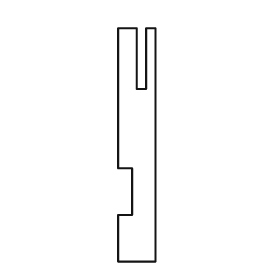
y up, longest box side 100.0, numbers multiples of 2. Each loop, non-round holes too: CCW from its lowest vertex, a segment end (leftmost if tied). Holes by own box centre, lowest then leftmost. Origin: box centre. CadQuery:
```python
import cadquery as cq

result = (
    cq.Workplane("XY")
    .moveTo(-8.0, -50.0)
    .lineTo(8.0, -50.0)
    .lineTo(8.0, 50.0)
    .lineTo(4.0, 50.0)
    .lineTo(4.0, 24.0)
    .lineTo(0.0, 24.0)
    .lineTo(0.0, 50.0)
    .lineTo(-8.0, 50.0)
    .lineTo(-8.0, -10.0)
    .lineTo(-2.0, -10.0)
    .lineTo(-2.0, -30.0)
    .lineTo(-8.0, -30.0)
    .close()
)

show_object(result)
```